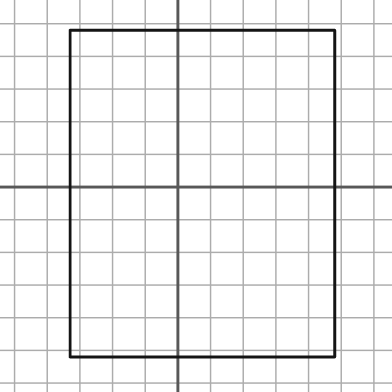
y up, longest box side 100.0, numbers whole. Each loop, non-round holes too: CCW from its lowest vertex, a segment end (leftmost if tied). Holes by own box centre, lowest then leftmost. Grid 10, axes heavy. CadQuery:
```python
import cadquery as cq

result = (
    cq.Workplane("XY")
    .moveTo(-33.0, -52.0)
    .lineTo(48.0, -52.0)
    .lineTo(48.0, 48.0)
    .lineTo(-33.0, 48.0)
    .close()
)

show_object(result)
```